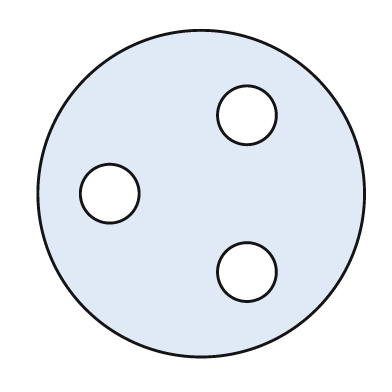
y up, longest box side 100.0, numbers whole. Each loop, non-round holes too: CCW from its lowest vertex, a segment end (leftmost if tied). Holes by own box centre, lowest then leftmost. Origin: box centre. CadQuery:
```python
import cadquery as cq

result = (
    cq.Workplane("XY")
    .moveTo(0.0, 0.0)
    .circle(50.0)
    .moveTo(14.0, -24.0)
    .circle(9.0)
    .moveTo(-28.0, 0.0)
    .circle(9.0)
    .moveTo(14.0, 24.0)
    .circle(9.0)
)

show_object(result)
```